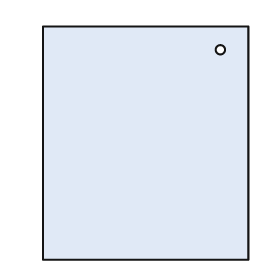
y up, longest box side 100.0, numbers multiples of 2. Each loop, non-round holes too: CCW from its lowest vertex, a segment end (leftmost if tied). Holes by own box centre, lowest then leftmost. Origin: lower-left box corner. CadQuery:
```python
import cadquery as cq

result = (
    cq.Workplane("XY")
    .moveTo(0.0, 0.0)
    .lineTo(88.0, 0.0)
    .lineTo(88.0, 100.0)
    .lineTo(0.0, 100.0)
    .close()
    .moveTo(76.0, 90.0)
    .circle(2.0)
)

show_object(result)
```